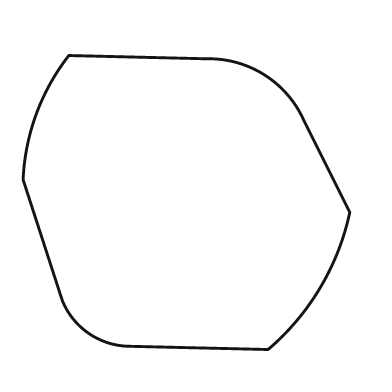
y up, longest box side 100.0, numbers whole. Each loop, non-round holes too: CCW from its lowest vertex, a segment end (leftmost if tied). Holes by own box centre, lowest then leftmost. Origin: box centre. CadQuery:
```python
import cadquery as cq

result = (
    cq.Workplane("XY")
    .moveTo(25.0, -45.0)
    .threePointArc((41.0, -26.0), (50.0, -3.0))
    .lineTo(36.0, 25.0)
    .threePointArc((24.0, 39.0), (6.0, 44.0))
    .lineTo(-36.0, 45.0)
    .threePointArc((-46.0, 27.0), (-50.0, 7.0))
    .lineTo(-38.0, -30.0)
    .threePointArc((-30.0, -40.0), (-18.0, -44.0))
    .close()
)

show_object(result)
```